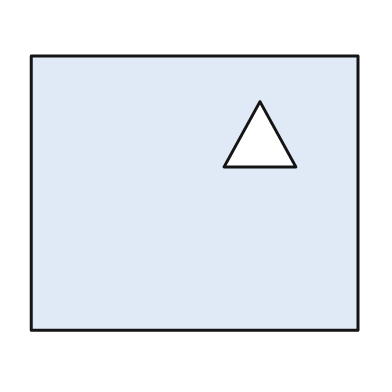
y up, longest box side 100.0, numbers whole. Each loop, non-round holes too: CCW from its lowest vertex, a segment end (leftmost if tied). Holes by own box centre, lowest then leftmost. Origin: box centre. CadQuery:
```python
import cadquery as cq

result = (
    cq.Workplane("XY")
    .moveTo(-50.0, -42.0)
    .lineTo(50.0, -42.0)
    .lineTo(50.0, 42.0)
    .lineTo(-50.0, 42.0)
    .close()
    .moveTo(9.0, 8.0)
    .lineTo(31.0, 8.0)
    .lineTo(20.0, 28.0)
    .close()
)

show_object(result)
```